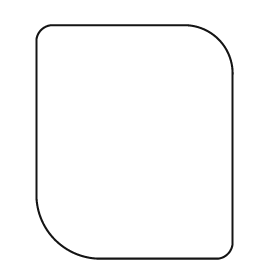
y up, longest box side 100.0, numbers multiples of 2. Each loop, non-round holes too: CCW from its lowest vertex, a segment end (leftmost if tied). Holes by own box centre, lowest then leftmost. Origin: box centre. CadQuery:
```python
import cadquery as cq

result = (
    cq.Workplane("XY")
    .moveTo(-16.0, -50.0)
    .lineTo(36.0, -50.0)
    .threePointArc((40.0, -48.0), (42.0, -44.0))
    .lineTo(42.0, 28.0)
    .threePointArc((36.0, 44.0), (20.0, 50.0))
    .lineTo(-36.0, 50.0)
    .threePointArc((-40.0, 48.0), (-42.0, 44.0))
    .lineTo(-42.0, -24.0)
    .threePointArc((-34.0, -42.0), (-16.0, -50.0))
    .close()
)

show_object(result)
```